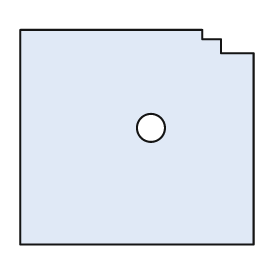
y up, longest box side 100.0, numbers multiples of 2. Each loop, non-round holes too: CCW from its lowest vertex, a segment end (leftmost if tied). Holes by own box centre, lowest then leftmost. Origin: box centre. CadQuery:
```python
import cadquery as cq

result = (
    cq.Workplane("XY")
    .moveTo(-50.0, -46.0)
    .lineTo(50.0, -46.0)
    .lineTo(50.0, 36.0)
    .lineTo(36.0, 36.0)
    .lineTo(36.0, 42.0)
    .lineTo(28.0, 42.0)
    .lineTo(28.0, 46.0)
    .lineTo(-50.0, 46.0)
    .close()
    .moveTo(6.0, 4.0)
    .circle(6.0)
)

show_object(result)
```